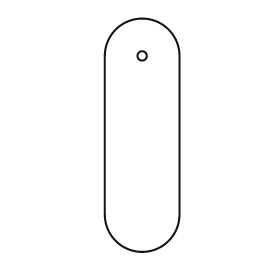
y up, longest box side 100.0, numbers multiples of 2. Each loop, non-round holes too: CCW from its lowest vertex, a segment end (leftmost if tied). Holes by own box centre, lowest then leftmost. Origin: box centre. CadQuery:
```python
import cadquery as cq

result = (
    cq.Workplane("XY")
    .moveTo(-16.0, -34.0)
    .threePointArc((0.0, -50.0), (16.0, -34.0))
    .lineTo(16.0, 34.0)
    .threePointArc((0.0, 50.0), (-16.0, 34.0))
    .close()
    .moveTo(0.0, 34.0)
    .circle(2.0)
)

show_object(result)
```